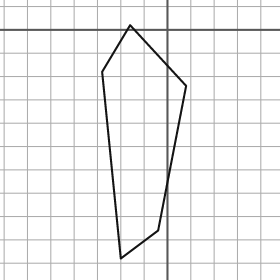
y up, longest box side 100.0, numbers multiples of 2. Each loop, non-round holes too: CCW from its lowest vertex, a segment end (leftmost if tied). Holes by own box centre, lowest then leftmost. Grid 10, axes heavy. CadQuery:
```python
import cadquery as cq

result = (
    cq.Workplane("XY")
    .moveTo(-20.0, -98.0)
    .lineTo(-4.0, -86.0)
    .lineTo(8.0, -24.0)
    .lineTo(-16.0, 2.0)
    .lineTo(-28.0, -18.0)
    .close()
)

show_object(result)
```